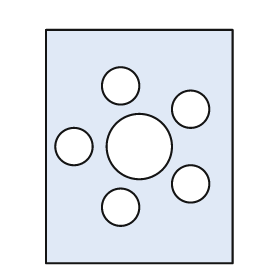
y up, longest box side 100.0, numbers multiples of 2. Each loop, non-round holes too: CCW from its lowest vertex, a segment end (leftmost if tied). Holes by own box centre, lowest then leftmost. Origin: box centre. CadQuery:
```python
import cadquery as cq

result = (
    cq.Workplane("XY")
    .moveTo(-40.0, -50.0)
    .lineTo(40.0, -50.0)
    .lineTo(40.0, 50.0)
    .lineTo(-40.0, 50.0)
    .close()
    .moveTo(-8.0, -26.0)
    .circle(8.0)
    .moveTo(22.0, -16.0)
    .circle(8.0)
    .moveTo(-28.0, 0.0)
    .circle(8.0)
    .moveTo(0.0, 0.0)
    .circle(14.0)
    .moveTo(22.0, 16.0)
    .circle(8.0)
    .moveTo(-8.0, 26.0)
    .circle(8.0)
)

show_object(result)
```